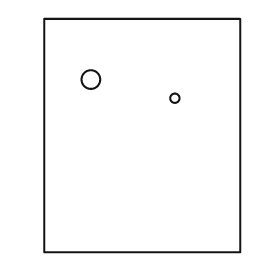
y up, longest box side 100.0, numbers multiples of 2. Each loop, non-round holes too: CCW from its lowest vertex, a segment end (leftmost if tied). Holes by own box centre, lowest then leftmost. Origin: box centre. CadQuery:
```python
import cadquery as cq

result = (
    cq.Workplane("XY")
    .moveTo(-42.0, -50.0)
    .lineTo(42.0, -50.0)
    .lineTo(42.0, 50.0)
    .lineTo(-42.0, 50.0)
    .close()
    .moveTo(14.0, 16.0)
    .circle(2.0)
    .moveTo(-22.0, 24.0)
    .circle(4.0)
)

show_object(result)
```